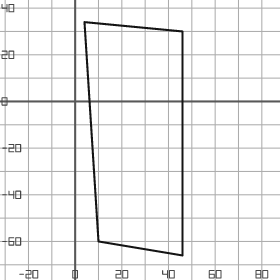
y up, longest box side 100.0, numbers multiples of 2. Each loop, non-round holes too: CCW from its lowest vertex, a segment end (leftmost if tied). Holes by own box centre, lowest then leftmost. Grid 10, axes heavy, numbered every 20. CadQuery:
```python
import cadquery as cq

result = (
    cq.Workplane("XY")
    .moveTo(46.0, -66.0)
    .lineTo(46.0, 30.0)
    .lineTo(4.0, 34.0)
    .lineTo(10.0, -60.0)
    .close()
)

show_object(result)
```